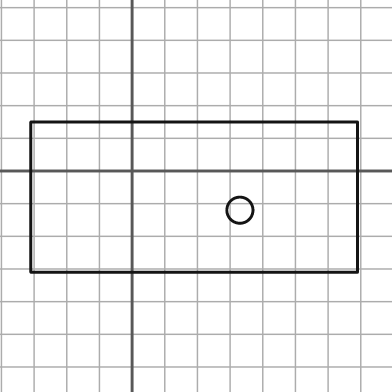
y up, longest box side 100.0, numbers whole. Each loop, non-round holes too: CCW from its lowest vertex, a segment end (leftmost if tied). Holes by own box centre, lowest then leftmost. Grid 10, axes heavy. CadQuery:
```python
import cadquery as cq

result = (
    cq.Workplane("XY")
    .moveTo(-31.0, -31.0)
    .lineTo(69.0, -31.0)
    .lineTo(69.0, 15.0)
    .lineTo(-31.0, 15.0)
    .close()
    .moveTo(33.0, -12.0)
    .circle(4.0)
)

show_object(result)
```